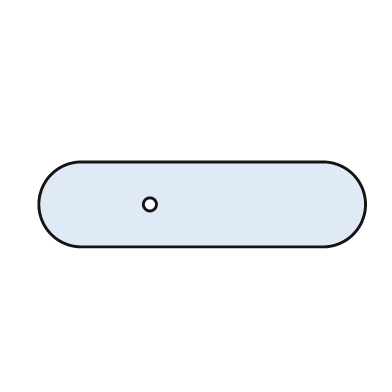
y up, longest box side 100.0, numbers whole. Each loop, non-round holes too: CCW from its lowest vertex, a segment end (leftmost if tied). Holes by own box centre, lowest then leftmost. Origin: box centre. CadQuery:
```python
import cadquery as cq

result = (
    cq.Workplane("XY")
    .moveTo(-37.0, -13.0)
    .lineTo(37.0, -13.0)
    .threePointArc((50.0, 0.0), (37.0, 13.0))
    .lineTo(-37.0, 13.0)
    .threePointArc((-50.0, 0.0), (-37.0, -13.0))
    .close()
    .moveTo(-16.0, 0.0)
    .circle(2.0)
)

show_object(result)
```